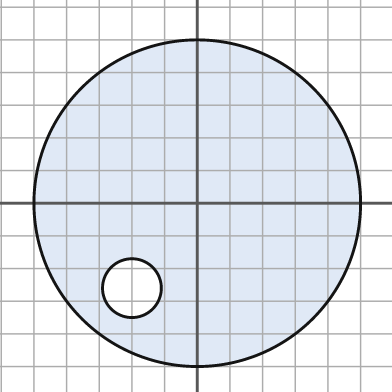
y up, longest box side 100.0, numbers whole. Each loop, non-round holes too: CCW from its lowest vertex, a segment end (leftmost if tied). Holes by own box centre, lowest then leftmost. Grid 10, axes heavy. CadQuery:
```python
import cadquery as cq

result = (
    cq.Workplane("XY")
    .moveTo(0.0, 0.0)
    .circle(50.0)
    .moveTo(-20.0, -26.0)
    .circle(9.0)
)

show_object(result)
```